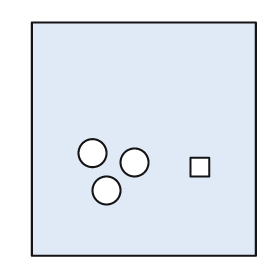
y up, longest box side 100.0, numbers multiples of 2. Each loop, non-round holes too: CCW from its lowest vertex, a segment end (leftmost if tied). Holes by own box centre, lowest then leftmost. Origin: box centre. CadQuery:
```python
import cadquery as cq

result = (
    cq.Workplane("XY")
    .moveTo(-48.0, -50.0)
    .lineTo(48.0, -50.0)
    .lineTo(48.0, 50.0)
    .lineTo(-48.0, 50.0)
    .close()
    .moveTo(-16.0, -22.0)
    .circle(6.0)
    .moveTo(20.0, -16.0)
    .lineTo(28.0, -16.0)
    .lineTo(28.0, -8.0)
    .lineTo(20.0, -8.0)
    .close()
    .moveTo(-4.0, -10.0)
    .circle(6.0)
    .moveTo(-22.0, -6.0)
    .circle(6.0)
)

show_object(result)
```